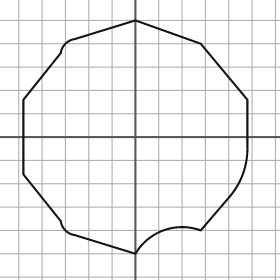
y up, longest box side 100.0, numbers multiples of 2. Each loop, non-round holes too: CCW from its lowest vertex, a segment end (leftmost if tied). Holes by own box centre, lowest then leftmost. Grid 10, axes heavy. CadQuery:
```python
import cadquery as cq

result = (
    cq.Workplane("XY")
    .moveTo(0.0, -50.0)
    .threePointArc((12.0, -40.0), (28.0, -40.0))
    .lineTo(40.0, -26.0)
    .threePointArc((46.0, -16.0), (48.0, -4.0))
    .lineTo(48.0, 16.0)
    .lineTo(28.0, 40.0)
    .lineTo(0.0, 50.0)
    .lineTo(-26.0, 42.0)
    .threePointArc((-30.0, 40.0), (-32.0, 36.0))
    .lineTo(-48.0, 16.0)
    .lineTo(-48.0, -16.0)
    .lineTo(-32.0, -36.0)
    .threePointArc((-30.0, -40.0), (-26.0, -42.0))
    .close()
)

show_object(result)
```